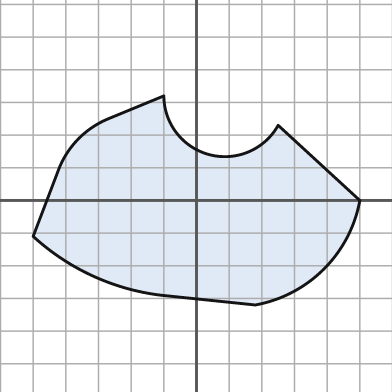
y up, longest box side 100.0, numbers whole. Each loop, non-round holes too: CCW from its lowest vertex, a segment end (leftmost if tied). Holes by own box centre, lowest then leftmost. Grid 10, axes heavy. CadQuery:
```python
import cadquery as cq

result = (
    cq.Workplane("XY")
    .moveTo(18.0, -32.0)
    .threePointArc((39.0, -21.0), (50.0, 0.0))
    .lineTo(25.0, 23.0)
    .threePointArc((4.0, 14.0), (-10.0, 32.0))
    .lineTo(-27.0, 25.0)
    .threePointArc((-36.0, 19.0), (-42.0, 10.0))
    .lineTo(-50.0, -11.0)
    .threePointArc((-32.0, -23.0), (-11.0, -29.0))
    .close()
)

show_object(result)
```